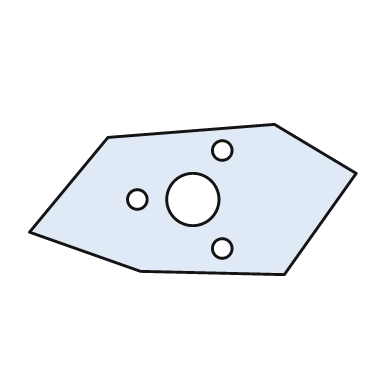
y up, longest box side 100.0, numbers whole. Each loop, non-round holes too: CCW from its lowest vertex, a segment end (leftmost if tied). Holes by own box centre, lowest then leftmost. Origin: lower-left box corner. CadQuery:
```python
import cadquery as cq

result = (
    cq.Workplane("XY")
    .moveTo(78.0, 0.0)
    .lineTo(100.0, 31.0)
    .lineTo(75.0, 46.0)
    .lineTo(24.0, 42.0)
    .lineTo(0.0, 13.0)
    .lineTo(34.0, 1.0)
    .close()
    .moveTo(59.0, 8.0)
    .circle(3.0)
    .moveTo(33.0, 23.0)
    .circle(3.0)
    .moveTo(50.0, 23.0)
    .circle(8.0)
    .moveTo(59.0, 38.0)
    .circle(3.0)
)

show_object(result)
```